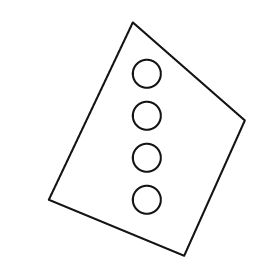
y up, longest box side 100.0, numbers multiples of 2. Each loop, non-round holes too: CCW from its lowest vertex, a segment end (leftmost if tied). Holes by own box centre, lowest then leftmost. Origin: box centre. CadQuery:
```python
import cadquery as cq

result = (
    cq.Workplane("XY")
    .moveTo(16.0, -50.0)
    .lineTo(42.0, 8.0)
    .lineTo(-6.0, 50.0)
    .lineTo(-42.0, -26.0)
    .close()
    .moveTo(0.0, -26.0)
    .circle(6.0)
    .moveTo(0.0, -8.0)
    .circle(6.0)
    .moveTo(0.0, 10.0)
    .circle(6.0)
    .moveTo(0.0, 28.0)
    .circle(6.0)
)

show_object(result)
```